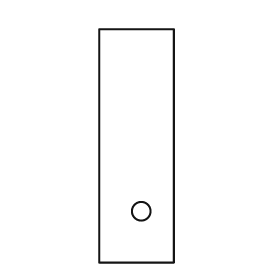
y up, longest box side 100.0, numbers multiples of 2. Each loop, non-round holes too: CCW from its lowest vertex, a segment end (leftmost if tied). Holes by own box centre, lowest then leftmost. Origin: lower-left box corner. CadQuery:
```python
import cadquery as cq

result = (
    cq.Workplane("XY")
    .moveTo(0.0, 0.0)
    .lineTo(32.0, 0.0)
    .lineTo(32.0, 100.0)
    .lineTo(0.0, 100.0)
    .close()
    .moveTo(18.0, 22.0)
    .circle(4.0)
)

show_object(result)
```